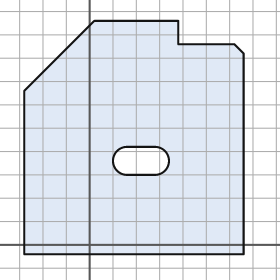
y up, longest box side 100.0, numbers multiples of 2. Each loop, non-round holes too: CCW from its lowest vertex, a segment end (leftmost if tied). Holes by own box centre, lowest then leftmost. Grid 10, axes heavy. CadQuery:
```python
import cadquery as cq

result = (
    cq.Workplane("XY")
    .moveTo(-28.0, -4.0)
    .lineTo(66.0, -4.0)
    .lineTo(66.0, 82.0)
    .lineTo(62.0, 86.0)
    .lineTo(38.0, 86.0)
    .lineTo(38.0, 96.0)
    .lineTo(2.0, 96.0)
    .lineTo(-28.0, 66.0)
    .close()
    .moveTo(16.0, 30.0)
    .lineTo(28.0, 30.0)
    .threePointArc((34.0, 36.0), (28.0, 42.0))
    .lineTo(16.0, 42.0)
    .threePointArc((10.0, 36.0), (16.0, 30.0))
    .close()
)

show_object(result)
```